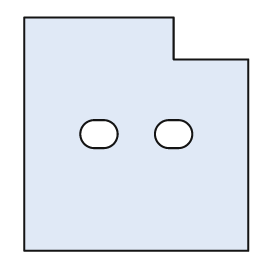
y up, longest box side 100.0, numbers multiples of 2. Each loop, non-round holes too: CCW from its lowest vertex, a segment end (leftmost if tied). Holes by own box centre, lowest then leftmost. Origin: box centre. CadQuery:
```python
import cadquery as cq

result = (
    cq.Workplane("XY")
    .moveTo(-48.0, -50.0)
    .lineTo(48.0, -50.0)
    .lineTo(48.0, 32.0)
    .lineTo(16.0, 32.0)
    .lineTo(16.0, 50.0)
    .lineTo(-48.0, 50.0)
    .close()
    .moveTo(-18.0, -6.0)
    .lineTo(-14.0, -6.0)
    .threePointArc((-8.0, 0.0), (-14.0, 6.0))
    .lineTo(-18.0, 6.0)
    .threePointArc((-24.0, 0.0), (-18.0, -6.0))
    .close()
    .moveTo(14.0, -6.0)
    .lineTo(18.0, -6.0)
    .threePointArc((24.0, 0.0), (18.0, 6.0))
    .lineTo(14.0, 6.0)
    .threePointArc((8.0, 0.0), (14.0, -6.0))
    .close()
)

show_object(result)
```